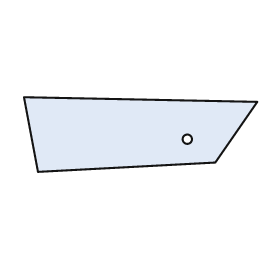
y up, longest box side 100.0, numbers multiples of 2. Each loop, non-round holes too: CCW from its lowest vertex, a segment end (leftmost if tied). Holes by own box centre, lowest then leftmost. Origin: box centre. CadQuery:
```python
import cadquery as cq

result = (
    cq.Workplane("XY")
    .moveTo(-44.0, -16.0)
    .lineTo(32.0, -12.0)
    .lineTo(50.0, 14.0)
    .lineTo(-50.0, 16.0)
    .close()
    .moveTo(20.0, -2.0)
    .circle(2.0)
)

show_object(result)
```